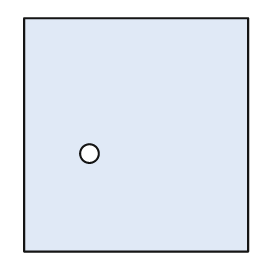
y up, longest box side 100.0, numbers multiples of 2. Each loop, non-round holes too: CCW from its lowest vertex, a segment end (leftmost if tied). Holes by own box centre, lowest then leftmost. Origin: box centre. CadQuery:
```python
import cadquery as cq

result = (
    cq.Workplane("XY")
    .moveTo(-48.0, -50.0)
    .lineTo(48.0, -50.0)
    .lineTo(48.0, 50.0)
    .lineTo(-48.0, 50.0)
    .close()
    .moveTo(-20.0, -8.0)
    .circle(4.0)
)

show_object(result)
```